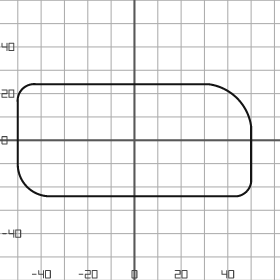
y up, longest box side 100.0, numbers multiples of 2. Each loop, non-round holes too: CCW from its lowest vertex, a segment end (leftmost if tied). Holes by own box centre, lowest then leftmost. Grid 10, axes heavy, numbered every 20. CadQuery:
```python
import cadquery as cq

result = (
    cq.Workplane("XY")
    .moveTo(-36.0, -24.0)
    .lineTo(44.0, -24.0)
    .threePointArc((48.0, -22.0), (50.0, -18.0))
    .lineTo(50.0, 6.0)
    .threePointArc((44.0, 18.0), (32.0, 24.0))
    .lineTo(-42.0, 24.0)
    .threePointArc((-48.0, 22.0), (-50.0, 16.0))
    .lineTo(-50.0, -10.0)
    .threePointArc((-46.0, -20.0), (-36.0, -24.0))
    .close()
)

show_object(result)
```